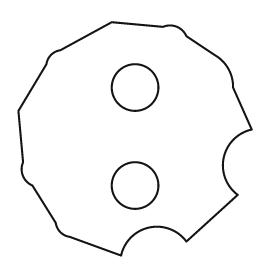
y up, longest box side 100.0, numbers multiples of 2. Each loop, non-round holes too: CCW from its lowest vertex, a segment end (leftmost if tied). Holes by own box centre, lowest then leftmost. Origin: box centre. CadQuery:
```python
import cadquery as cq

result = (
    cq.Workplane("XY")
    .moveTo(-6.0, -50.0)
    .threePointArc((6.0, -38.0), (22.0, -44.0))
    .lineTo(44.0, -24.0)
    .threePointArc((38.0, -8.0), (50.0, 4.0))
    .lineTo(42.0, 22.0)
    .threePointArc((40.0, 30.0), (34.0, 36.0))
    .lineTo(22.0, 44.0)
    .threePointArc((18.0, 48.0), (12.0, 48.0))
    .lineTo(-10.0, 50.0)
    .lineTo(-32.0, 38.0)
    .threePointArc((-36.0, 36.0), (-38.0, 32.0))
    .lineTo(-50.0, 12.0)
    .lineTo(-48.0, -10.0)
    .threePointArc((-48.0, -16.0), (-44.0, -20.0))
    .lineTo(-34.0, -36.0)
    .threePointArc((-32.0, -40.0), (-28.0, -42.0))
    .close()
    .moveTo(0.0, -20.0)
    .circle(10.0)
    .moveTo(0.0, 22.0)
    .circle(10.0)
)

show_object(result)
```